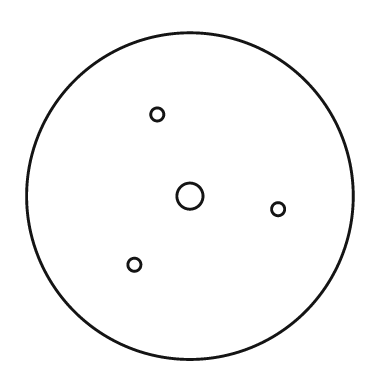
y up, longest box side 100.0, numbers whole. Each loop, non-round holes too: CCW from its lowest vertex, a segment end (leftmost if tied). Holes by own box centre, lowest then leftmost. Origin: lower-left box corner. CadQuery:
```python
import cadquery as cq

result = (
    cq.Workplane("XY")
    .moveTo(50.0, 50.0)
    .circle(50.0)
    .moveTo(33.0, 29.0)
    .circle(2.0)
    .moveTo(77.0, 46.0)
    .circle(2.0)
    .moveTo(50.0, 50.0)
    .circle(4.0)
    .moveTo(40.0, 75.0)
    .circle(2.0)
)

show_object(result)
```